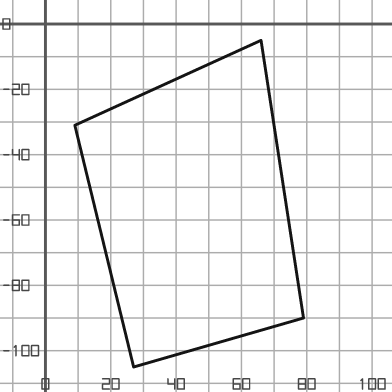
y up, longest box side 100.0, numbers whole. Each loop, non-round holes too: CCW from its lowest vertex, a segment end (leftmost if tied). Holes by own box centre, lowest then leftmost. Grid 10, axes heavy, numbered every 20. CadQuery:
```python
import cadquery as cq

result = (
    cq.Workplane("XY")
    .moveTo(27.0, -105.0)
    .lineTo(79.0, -90.0)
    .lineTo(66.0, -5.0)
    .lineTo(9.0, -31.0)
    .close()
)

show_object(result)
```